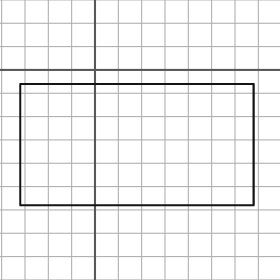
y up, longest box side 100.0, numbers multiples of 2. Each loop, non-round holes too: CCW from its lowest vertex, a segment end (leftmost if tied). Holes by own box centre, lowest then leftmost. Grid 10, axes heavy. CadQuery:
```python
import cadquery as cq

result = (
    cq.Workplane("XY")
    .moveTo(-32.0, -58.0)
    .lineTo(68.0, -58.0)
    .lineTo(68.0, -6.0)
    .lineTo(-32.0, -6.0)
    .close()
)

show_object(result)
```